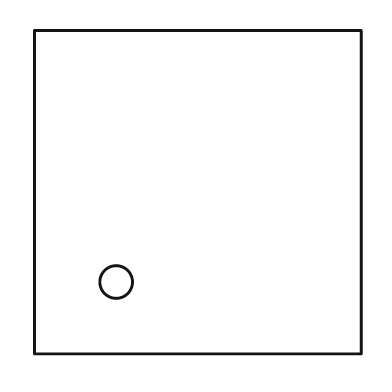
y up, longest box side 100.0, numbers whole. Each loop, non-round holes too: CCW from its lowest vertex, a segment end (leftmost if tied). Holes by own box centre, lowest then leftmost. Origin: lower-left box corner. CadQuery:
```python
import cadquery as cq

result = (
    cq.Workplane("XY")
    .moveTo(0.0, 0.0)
    .lineTo(100.0, 0.0)
    .lineTo(100.0, 99.0)
    .lineTo(0.0, 99.0)
    .close()
    .moveTo(25.0, 22.0)
    .circle(5.0)
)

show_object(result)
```